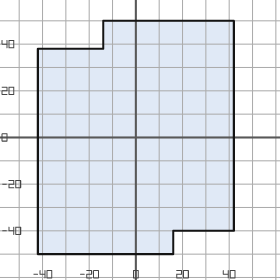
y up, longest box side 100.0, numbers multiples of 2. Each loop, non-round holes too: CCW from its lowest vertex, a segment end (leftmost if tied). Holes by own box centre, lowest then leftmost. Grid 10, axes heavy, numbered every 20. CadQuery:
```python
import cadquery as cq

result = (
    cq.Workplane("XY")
    .moveTo(-42.0, -50.0)
    .lineTo(16.0, -50.0)
    .lineTo(16.0, -40.0)
    .lineTo(42.0, -40.0)
    .lineTo(42.0, 50.0)
    .lineTo(-14.0, 50.0)
    .lineTo(-14.0, 38.0)
    .lineTo(-42.0, 38.0)
    .close()
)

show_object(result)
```